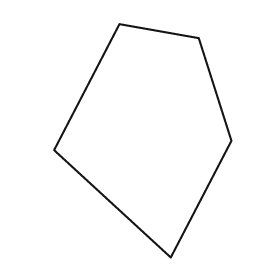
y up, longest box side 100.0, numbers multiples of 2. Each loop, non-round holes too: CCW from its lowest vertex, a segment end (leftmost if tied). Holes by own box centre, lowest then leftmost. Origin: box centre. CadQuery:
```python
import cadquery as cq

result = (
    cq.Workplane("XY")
    .moveTo(12.0, -50.0)
    .lineTo(38.0, 0.0)
    .lineTo(24.0, 44.0)
    .lineTo(-10.0, 50.0)
    .lineTo(-38.0, -4.0)
    .close()
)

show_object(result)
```